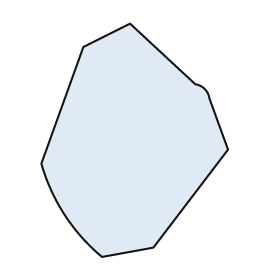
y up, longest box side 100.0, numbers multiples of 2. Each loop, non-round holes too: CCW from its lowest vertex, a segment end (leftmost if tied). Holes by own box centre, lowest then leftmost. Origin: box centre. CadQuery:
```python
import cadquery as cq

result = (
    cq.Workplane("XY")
    .moveTo(-14.0, -50.0)
    .lineTo(8.0, -46.0)
    .lineTo(40.0, -4.0)
    .lineTo(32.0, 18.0)
    .threePointArc((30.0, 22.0), (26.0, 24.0))
    .lineTo(-2.0, 50.0)
    .lineTo(-22.0, 40.0)
    .lineTo(-40.0, -10.0)
    .threePointArc((-30.0, -32.0), (-14.0, -50.0))
    .close()
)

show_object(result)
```